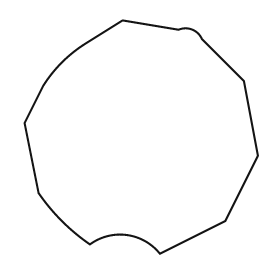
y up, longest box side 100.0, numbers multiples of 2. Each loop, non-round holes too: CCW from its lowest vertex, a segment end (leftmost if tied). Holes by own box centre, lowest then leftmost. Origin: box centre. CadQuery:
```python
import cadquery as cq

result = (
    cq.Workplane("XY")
    .moveTo(8.0, -50.0)
    .lineTo(36.0, -36.0)
    .lineTo(50.0, -8.0)
    .lineTo(44.0, 24.0)
    .lineTo(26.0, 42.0)
    .threePointArc((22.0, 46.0), (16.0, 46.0))
    .lineTo(-8.0, 50.0)
    .lineTo(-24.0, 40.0)
    .threePointArc((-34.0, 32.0), (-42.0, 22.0))
    .lineTo(-50.0, 6.0)
    .lineTo(-44.0, -24.0)
    .threePointArc((-34.0, -36.0), (-22.0, -46.0))
    .threePointArc((-6.0, -42.0), (8.0, -50.0))
    .close()
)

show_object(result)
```